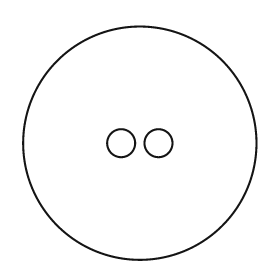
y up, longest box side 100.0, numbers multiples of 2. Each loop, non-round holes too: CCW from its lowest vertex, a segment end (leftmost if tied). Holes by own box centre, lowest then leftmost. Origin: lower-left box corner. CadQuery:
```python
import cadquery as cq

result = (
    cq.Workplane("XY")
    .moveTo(50.0, 50.0)
    .circle(50.0)
    .moveTo(42.0, 50.0)
    .circle(6.0)
    .moveTo(58.0, 50.0)
    .circle(6.0)
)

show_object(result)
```